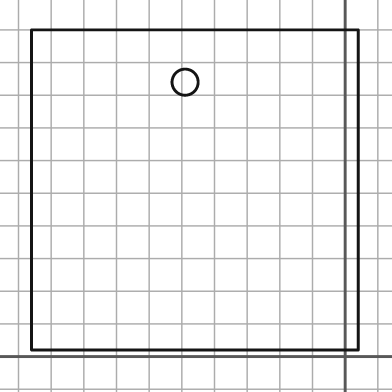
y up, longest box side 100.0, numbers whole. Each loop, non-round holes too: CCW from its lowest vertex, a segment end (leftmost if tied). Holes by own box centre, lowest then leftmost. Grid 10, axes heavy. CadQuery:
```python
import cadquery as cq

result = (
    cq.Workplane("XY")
    .moveTo(-96.0, 2.0)
    .lineTo(4.0, 2.0)
    .lineTo(4.0, 100.0)
    .lineTo(-96.0, 100.0)
    .close()
    .moveTo(-49.0, 84.0)
    .circle(4.0)
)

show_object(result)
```